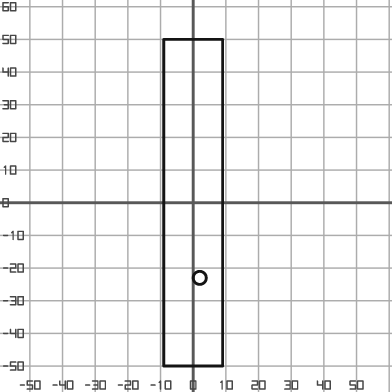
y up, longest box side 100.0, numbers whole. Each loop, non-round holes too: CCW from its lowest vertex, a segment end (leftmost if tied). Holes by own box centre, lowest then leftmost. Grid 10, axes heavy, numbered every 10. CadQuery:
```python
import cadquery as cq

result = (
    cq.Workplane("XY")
    .moveTo(-9.0, -50.0)
    .lineTo(9.0, -50.0)
    .lineTo(9.0, 50.0)
    .lineTo(-9.0, 50.0)
    .close()
    .moveTo(2.0, -23.0)
    .circle(2.0)
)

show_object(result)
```